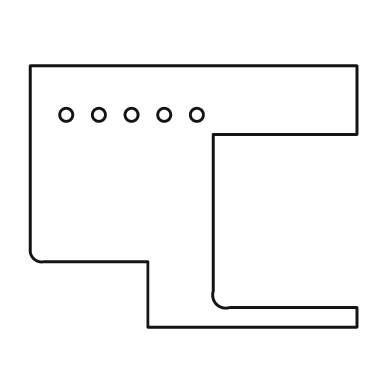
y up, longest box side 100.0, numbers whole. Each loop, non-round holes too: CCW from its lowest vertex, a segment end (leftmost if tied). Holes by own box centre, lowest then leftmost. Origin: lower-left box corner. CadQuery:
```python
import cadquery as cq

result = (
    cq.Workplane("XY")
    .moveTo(36.0, 0.0)
    .lineTo(100.0, 0.0)
    .lineTo(100.0, 6.0)
    .lineTo(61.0, 6.0)
    .threePointArc((57.0, 7.0), (56.0, 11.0))
    .lineTo(56.0, 59.0)
    .lineTo(100.0, 59.0)
    .lineTo(100.0, 80.0)
    .lineTo(0.0, 80.0)
    .lineTo(0.0, 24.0)
    .threePointArc((1.0, 21.0), (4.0, 20.0))
    .lineTo(36.0, 20.0)
    .close()
    .moveTo(11.0, 65.0)
    .circle(2.0)
    .moveTo(21.0, 65.0)
    .circle(2.0)
    .moveTo(31.0, 65.0)
    .circle(2.0)
    .moveTo(41.0, 65.0)
    .circle(2.0)
    .moveTo(51.0, 65.0)
    .circle(2.0)
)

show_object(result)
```